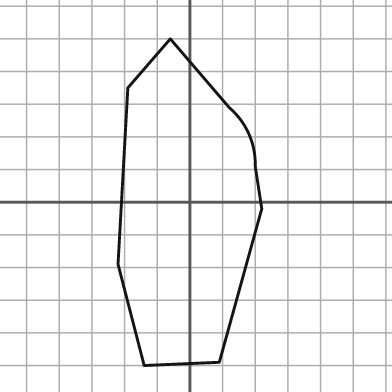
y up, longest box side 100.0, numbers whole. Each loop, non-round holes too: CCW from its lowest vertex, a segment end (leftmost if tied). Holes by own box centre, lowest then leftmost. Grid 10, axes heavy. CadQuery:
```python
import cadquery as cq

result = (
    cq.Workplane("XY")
    .moveTo(-14.0, -50.0)
    .lineTo(9.0, -49.0)
    .lineTo(22.0, -2.0)
    .lineTo(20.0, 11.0)
    .threePointArc((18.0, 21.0), (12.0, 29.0))
    .lineTo(-6.0, 50.0)
    .lineTo(-19.0, 35.0)
    .lineTo(-22.0, -19.0)
    .close()
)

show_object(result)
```